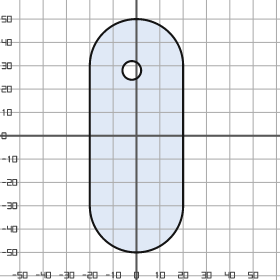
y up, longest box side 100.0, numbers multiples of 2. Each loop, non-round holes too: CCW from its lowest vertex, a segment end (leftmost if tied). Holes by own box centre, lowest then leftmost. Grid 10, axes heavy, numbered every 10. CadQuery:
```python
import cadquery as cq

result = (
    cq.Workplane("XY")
    .moveTo(-20.0, -30.0)
    .threePointArc((0.0, -50.0), (20.0, -30.0))
    .lineTo(20.0, 30.0)
    .threePointArc((0.0, 50.0), (-20.0, 30.0))
    .close()
    .moveTo(-2.0, 28.0)
    .circle(4.0)
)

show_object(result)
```